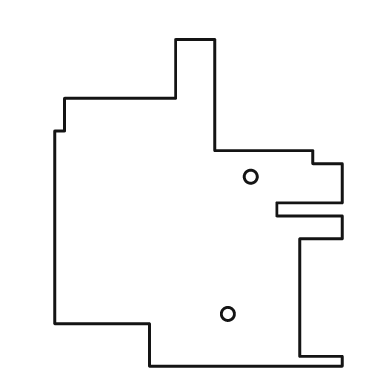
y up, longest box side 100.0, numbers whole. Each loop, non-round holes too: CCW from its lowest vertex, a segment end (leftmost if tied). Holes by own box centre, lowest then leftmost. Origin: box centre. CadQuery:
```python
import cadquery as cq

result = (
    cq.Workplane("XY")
    .moveTo(-15.0, -50.0)
    .lineTo(44.0, -50.0)
    .lineTo(44.0, -47.0)
    .lineTo(31.0, -47.0)
    .lineTo(31.0, -11.0)
    .lineTo(44.0, -11.0)
    .lineTo(44.0, -4.0)
    .lineTo(24.0, -4.0)
    .lineTo(24.0, 0.0)
    .lineTo(44.0, 0.0)
    .lineTo(44.0, 12.0)
    .lineTo(35.0, 12.0)
    .lineTo(35.0, 16.0)
    .lineTo(5.0, 16.0)
    .lineTo(5.0, 50.0)
    .lineTo(-7.0, 50.0)
    .lineTo(-7.0, 32.0)
    .lineTo(-41.0, 32.0)
    .lineTo(-41.0, 22.0)
    .lineTo(-44.0, 22.0)
    .lineTo(-44.0, -37.0)
    .lineTo(-15.0, -37.0)
    .close()
    .moveTo(9.0, -34.0)
    .circle(2.0)
    .moveTo(16.0, 8.0)
    .circle(2.0)
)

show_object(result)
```